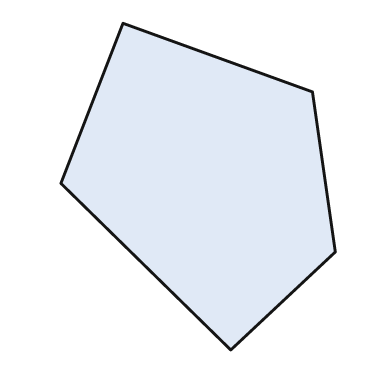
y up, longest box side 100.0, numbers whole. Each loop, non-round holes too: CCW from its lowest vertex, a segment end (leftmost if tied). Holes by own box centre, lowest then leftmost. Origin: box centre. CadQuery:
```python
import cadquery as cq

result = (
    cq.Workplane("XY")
    .moveTo(10.0, -50.0)
    .lineTo(42.0, -20.0)
    .lineTo(35.0, 29.0)
    .lineTo(-23.0, 50.0)
    .lineTo(-42.0, 1.0)
    .close()
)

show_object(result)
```